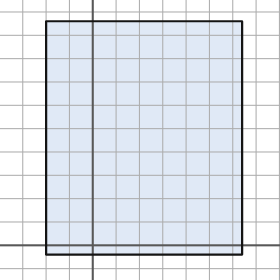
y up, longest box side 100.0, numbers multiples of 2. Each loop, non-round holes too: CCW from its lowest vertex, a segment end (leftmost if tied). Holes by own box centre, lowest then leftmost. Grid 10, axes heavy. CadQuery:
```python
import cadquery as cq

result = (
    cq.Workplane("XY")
    .moveTo(-20.0, -4.0)
    .lineTo(64.0, -4.0)
    .lineTo(64.0, 96.0)
    .lineTo(-20.0, 96.0)
    .close()
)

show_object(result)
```